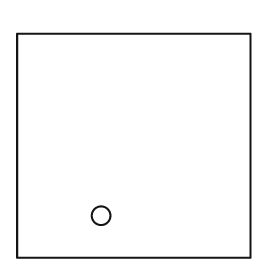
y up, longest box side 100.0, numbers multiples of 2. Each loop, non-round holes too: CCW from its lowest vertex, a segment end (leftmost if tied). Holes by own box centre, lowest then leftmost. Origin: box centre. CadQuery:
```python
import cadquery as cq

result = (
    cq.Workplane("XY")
    .moveTo(-50.0, -48.0)
    .lineTo(50.0, -48.0)
    .lineTo(50.0, 48.0)
    .lineTo(-50.0, 48.0)
    .close()
    .moveTo(-14.0, -30.0)
    .circle(4.0)
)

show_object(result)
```